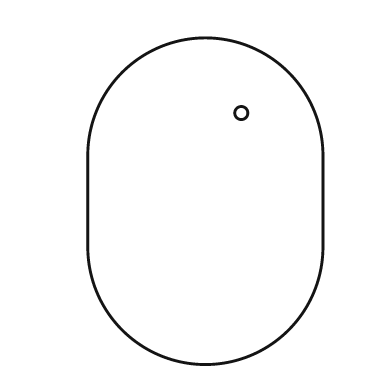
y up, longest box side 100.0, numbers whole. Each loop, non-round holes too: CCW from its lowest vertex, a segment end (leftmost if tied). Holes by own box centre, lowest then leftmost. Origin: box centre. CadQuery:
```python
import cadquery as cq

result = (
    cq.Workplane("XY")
    .moveTo(-36.0, -14.0)
    .threePointArc((0.0, -50.0), (36.0, -14.0))
    .lineTo(36.0, 14.0)
    .threePointArc((0.0, 50.0), (-36.0, 14.0))
    .close()
    .moveTo(11.0, 27.0)
    .circle(2.0)
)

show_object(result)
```